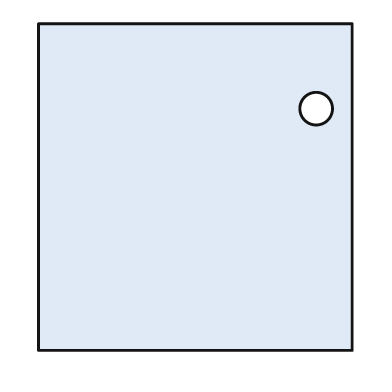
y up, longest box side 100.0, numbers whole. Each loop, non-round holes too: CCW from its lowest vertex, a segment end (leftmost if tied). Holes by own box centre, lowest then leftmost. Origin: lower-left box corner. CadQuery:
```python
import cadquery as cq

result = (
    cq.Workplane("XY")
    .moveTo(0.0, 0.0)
    .lineTo(96.0, 0.0)
    .lineTo(96.0, 100.0)
    .lineTo(0.0, 100.0)
    .close()
    .moveTo(85.0, 74.0)
    .circle(5.0)
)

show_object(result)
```